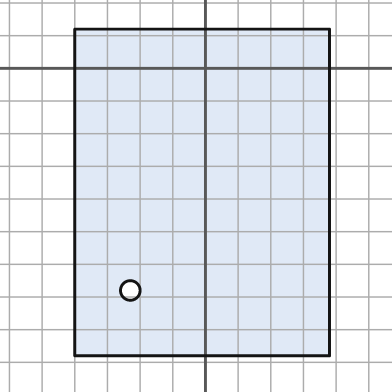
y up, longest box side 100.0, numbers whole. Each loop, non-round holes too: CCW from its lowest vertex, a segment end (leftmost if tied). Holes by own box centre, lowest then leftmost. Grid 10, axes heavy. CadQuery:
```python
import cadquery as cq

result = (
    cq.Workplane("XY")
    .moveTo(-40.0, -88.0)
    .lineTo(38.0, -88.0)
    .lineTo(38.0, 12.0)
    .lineTo(-40.0, 12.0)
    .close()
    .moveTo(-23.0, -68.0)
    .circle(3.0)
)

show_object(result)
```